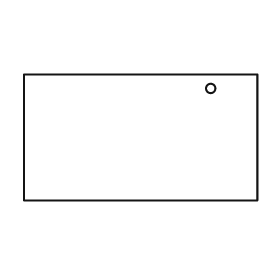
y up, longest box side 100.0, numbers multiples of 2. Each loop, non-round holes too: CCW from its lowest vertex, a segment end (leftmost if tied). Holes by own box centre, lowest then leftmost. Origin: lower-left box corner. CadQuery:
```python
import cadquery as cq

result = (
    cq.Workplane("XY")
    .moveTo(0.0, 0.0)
    .lineTo(100.0, 0.0)
    .lineTo(100.0, 54.0)
    .lineTo(0.0, 54.0)
    .close()
    .moveTo(80.0, 48.0)
    .circle(2.0)
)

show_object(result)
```